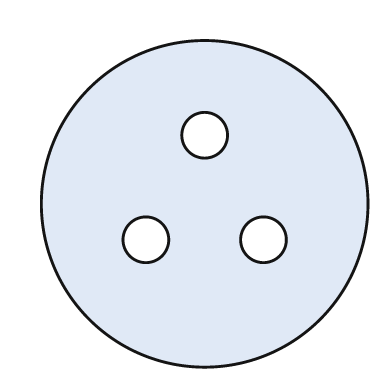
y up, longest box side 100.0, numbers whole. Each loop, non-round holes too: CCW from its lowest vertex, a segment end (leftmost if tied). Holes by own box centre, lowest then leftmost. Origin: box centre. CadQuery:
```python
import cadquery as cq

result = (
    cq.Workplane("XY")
    .moveTo(0.0, 0.0)
    .circle(50.0)
    .moveTo(-18.0, -11.0)
    .circle(7.0)
    .moveTo(18.0, -11.0)
    .circle(7.0)
    .moveTo(0.0, 21.0)
    .circle(7.0)
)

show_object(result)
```